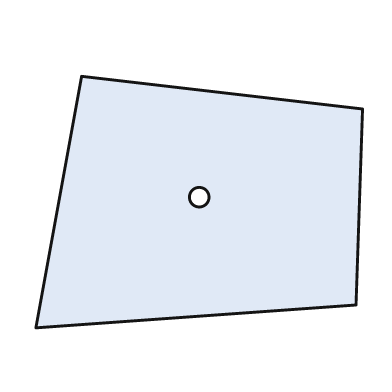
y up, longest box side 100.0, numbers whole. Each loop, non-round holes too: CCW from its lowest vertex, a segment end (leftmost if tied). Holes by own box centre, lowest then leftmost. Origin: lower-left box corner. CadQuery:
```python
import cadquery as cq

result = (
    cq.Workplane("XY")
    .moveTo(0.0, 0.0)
    .lineTo(98.0, 7.0)
    .lineTo(100.0, 67.0)
    .lineTo(14.0, 77.0)
    .close()
    .moveTo(50.0, 40.0)
    .circle(3.0)
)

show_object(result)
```